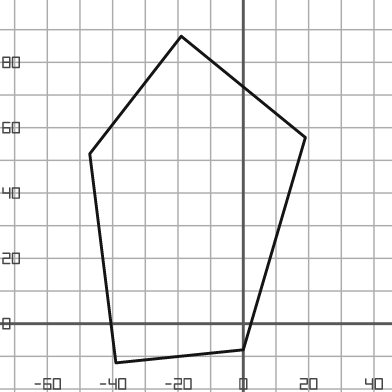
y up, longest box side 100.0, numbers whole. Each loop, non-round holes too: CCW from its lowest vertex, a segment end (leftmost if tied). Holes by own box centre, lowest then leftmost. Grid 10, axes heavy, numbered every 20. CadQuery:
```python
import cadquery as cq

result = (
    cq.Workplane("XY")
    .moveTo(-39.0, -12.0)
    .lineTo(0.0, -8.0)
    .lineTo(19.0, 57.0)
    .lineTo(-19.0, 88.0)
    .lineTo(-47.0, 52.0)
    .close()
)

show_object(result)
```